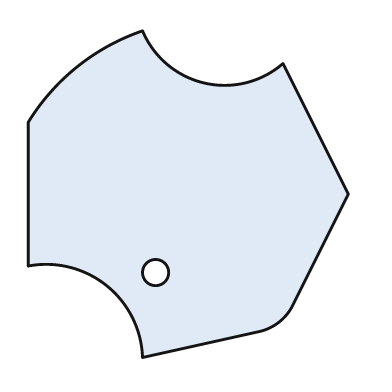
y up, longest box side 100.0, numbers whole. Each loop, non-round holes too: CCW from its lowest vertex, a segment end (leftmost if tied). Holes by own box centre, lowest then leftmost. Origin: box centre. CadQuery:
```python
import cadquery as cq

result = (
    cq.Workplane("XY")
    .moveTo(-14.0, -50.0)
    .lineTo(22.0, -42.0)
    .threePointArc((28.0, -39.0), (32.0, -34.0))
    .lineTo(49.0, 0.0)
    .lineTo(29.0, 40.0)
    .threePointArc((5.0, 34.0), (-14.0, 50.0))
    .threePointArc((-34.0, 39.0), (-49.0, 22.0))
    .lineTo(-49.0, -22.0)
    .threePointArc((-25.0, -28.0), (-14.0, -50.0))
    .close()
    .moveTo(-10.0, -24.0)
    .circle(4.0)
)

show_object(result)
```